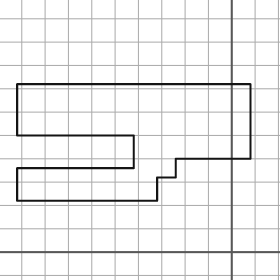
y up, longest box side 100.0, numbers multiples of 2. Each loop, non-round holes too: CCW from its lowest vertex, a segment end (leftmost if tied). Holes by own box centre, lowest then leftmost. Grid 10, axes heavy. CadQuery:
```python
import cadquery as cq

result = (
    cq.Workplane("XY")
    .moveTo(-92.0, 22.0)
    .lineTo(-32.0, 22.0)
    .lineTo(-32.0, 32.0)
    .lineTo(-24.0, 32.0)
    .lineTo(-24.0, 40.0)
    .lineTo(8.0, 40.0)
    .lineTo(8.0, 72.0)
    .lineTo(-92.0, 72.0)
    .lineTo(-92.0, 50.0)
    .lineTo(-42.0, 50.0)
    .lineTo(-42.0, 36.0)
    .lineTo(-92.0, 36.0)
    .close()
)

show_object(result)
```